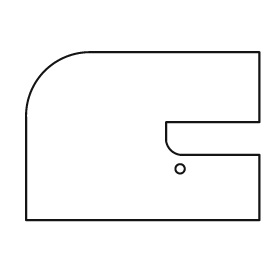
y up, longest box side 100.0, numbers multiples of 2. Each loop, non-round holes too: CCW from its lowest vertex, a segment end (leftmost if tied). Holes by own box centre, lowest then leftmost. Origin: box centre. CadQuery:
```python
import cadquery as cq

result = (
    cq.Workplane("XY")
    .moveTo(-50.0, -36.0)
    .lineTo(50.0, -36.0)
    .lineTo(50.0, -8.0)
    .lineTo(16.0, -8.0)
    .threePointArc((12.0, -6.0), (10.0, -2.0))
    .lineTo(10.0, 6.0)
    .lineTo(50.0, 6.0)
    .lineTo(50.0, 36.0)
    .lineTo(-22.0, 36.0)
    .threePointArc((-42.0, 28.0), (-50.0, 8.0))
    .close()
    .moveTo(16.0, -14.0)
    .circle(2.0)
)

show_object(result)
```